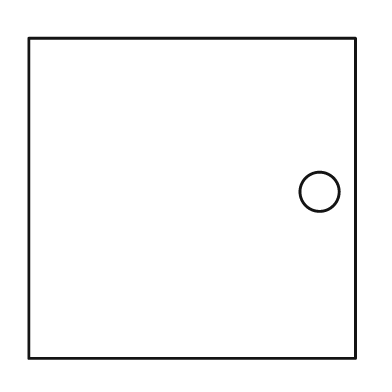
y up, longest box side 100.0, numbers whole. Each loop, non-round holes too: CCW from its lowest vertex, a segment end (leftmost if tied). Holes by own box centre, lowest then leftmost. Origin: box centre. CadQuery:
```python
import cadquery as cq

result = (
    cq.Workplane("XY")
    .moveTo(-50.0, -49.0)
    .lineTo(50.0, -49.0)
    .lineTo(50.0, 49.0)
    .lineTo(-50.0, 49.0)
    .close()
    .moveTo(39.0, 2.0)
    .circle(6.0)
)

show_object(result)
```